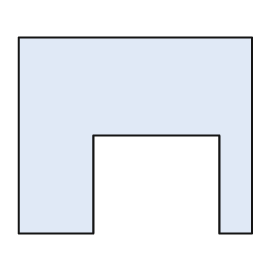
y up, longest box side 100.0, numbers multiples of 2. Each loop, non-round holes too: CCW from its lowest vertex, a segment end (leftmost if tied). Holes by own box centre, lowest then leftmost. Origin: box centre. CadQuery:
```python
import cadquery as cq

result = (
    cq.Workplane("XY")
    .moveTo(-50.0, -42.0)
    .lineTo(-18.0, -42.0)
    .lineTo(-18.0, 0.0)
    .lineTo(36.0, 0.0)
    .lineTo(36.0, -42.0)
    .lineTo(50.0, -42.0)
    .lineTo(50.0, 42.0)
    .lineTo(-50.0, 42.0)
    .close()
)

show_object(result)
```